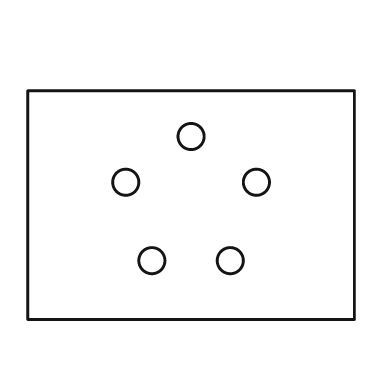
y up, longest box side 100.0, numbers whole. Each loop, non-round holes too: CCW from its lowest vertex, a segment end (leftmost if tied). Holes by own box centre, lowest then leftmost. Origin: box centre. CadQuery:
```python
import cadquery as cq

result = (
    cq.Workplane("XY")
    .moveTo(-50.0, -35.0)
    .lineTo(50.0, -35.0)
    .lineTo(50.0, 35.0)
    .lineTo(-50.0, 35.0)
    .close()
    .moveTo(-12.0, -17.0)
    .circle(4.0)
    .moveTo(12.0, -17.0)
    .circle(4.0)
    .moveTo(-20.0, 7.0)
    .circle(4.0)
    .moveTo(20.0, 7.0)
    .circle(4.0)
    .moveTo(0.0, 21.0)
    .circle(4.0)
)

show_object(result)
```